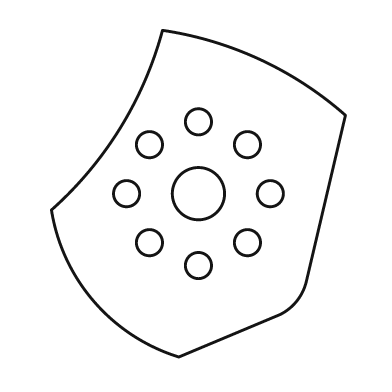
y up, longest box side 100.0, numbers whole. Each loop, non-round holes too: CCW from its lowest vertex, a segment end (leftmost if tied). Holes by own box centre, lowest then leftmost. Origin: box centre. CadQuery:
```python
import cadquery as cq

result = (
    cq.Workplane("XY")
    .moveTo(-6.0, -50.0)
    .lineTo(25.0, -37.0)
    .threePointArc((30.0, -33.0), (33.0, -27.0))
    .lineTo(45.0, 24.0)
    .threePointArc((19.0, 41.0), (-11.0, 50.0))
    .threePointArc((-24.0, 20.0), (-45.0, -5.0))
    .threePointArc((-32.0, -33.0), (-6.0, -50.0))
    .close()
    .moveTo(0.0, -22.0)
    .circle(4.0)
    .moveTo(-15.0, -15.0)
    .circle(4.0)
    .moveTo(15.0, -15.0)
    .circle(4.0)
    .moveTo(-22.0, 0.0)
    .circle(4.0)
    .moveTo(0.0, 0.0)
    .circle(8.0)
    .moveTo(22.0, 0.0)
    .circle(4.0)
    .moveTo(-15.0, 15.0)
    .circle(4.0)
    .moveTo(15.0, 15.0)
    .circle(4.0)
    .moveTo(0.0, 22.0)
    .circle(4.0)
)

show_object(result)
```